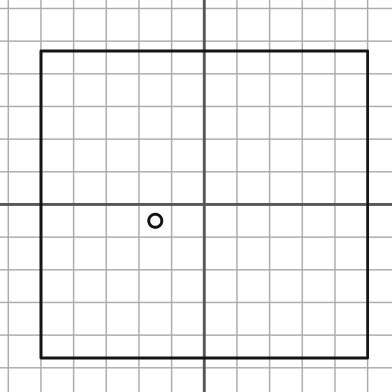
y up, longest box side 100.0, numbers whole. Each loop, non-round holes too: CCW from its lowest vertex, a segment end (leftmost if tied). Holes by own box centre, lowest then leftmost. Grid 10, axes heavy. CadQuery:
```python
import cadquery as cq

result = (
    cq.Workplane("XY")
    .moveTo(-50.0, -47.0)
    .lineTo(50.0, -47.0)
    .lineTo(50.0, 47.0)
    .lineTo(-50.0, 47.0)
    .close()
    .moveTo(-15.0, -5.0)
    .circle(2.0)
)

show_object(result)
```